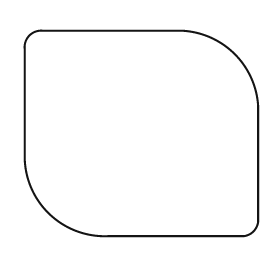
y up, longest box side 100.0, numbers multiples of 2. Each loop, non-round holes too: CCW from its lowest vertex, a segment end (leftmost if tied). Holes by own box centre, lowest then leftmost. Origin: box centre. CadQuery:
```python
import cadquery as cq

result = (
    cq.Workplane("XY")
    .moveTo(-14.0, -44.0)
    .lineTo(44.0, -44.0)
    .threePointArc((48.0, -42.0), (50.0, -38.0))
    .lineTo(50.0, 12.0)
    .threePointArc((40.0, 34.0), (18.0, 44.0))
    .lineTo(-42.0, 44.0)
    .threePointArc((-48.0, 42.0), (-50.0, 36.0))
    .lineTo(-50.0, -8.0)
    .threePointArc((-40.0, -34.0), (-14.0, -44.0))
    .close()
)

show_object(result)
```